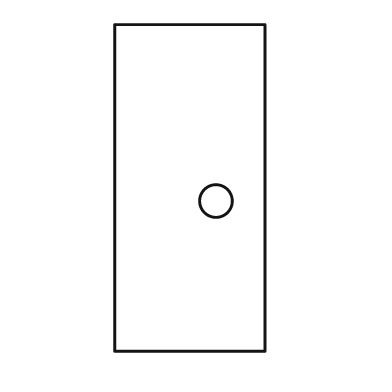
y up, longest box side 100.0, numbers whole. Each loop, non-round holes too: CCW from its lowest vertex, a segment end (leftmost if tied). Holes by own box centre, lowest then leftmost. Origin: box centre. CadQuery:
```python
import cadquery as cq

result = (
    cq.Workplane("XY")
    .moveTo(-23.0, -50.0)
    .lineTo(23.0, -50.0)
    .lineTo(23.0, 50.0)
    .lineTo(-23.0, 50.0)
    .close()
    .moveTo(8.0, -4.0)
    .circle(5.0)
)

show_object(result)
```